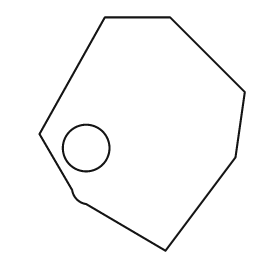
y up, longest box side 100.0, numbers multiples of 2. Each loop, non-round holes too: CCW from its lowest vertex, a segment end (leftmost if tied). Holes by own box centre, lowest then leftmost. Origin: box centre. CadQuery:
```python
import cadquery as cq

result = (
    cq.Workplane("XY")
    .moveTo(10.0, -50.0)
    .lineTo(40.0, -10.0)
    .lineTo(44.0, 18.0)
    .lineTo(12.0, 50.0)
    .lineTo(-16.0, 50.0)
    .lineTo(-44.0, 0.0)
    .lineTo(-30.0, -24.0)
    .threePointArc((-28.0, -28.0), (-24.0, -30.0))
    .close()
    .moveTo(-24.0, -6.0)
    .circle(10.0)
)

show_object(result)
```